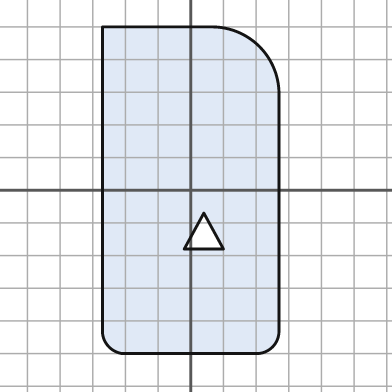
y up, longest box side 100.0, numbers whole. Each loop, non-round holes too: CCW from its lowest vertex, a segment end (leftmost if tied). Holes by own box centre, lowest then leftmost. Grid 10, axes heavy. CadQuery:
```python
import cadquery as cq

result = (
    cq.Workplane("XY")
    .moveTo(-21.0, -50.0)
    .lineTo(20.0, -50.0)
    .threePointArc((25.0, -48.0), (27.0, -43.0))
    .lineTo(27.0, 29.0)
    .threePointArc((21.0, 44.0), (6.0, 50.0))
    .lineTo(-27.0, 50.0)
    .lineTo(-27.0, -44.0)
    .threePointArc((-25.0, -48.0), (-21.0, -50.0))
    .close()
    .moveTo(-2.0, -18.0)
    .lineTo(10.0, -18.0)
    .lineTo(4.0, -7.0)
    .close()
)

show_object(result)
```